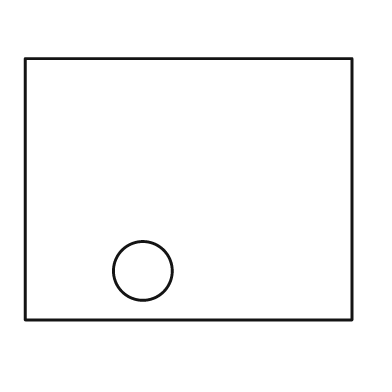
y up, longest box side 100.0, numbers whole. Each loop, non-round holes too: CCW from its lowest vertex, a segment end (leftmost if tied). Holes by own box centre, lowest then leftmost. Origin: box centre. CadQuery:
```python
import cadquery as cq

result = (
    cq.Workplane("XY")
    .moveTo(-50.0, -40.0)
    .lineTo(50.0, -40.0)
    .lineTo(50.0, 40.0)
    .lineTo(-50.0, 40.0)
    .close()
    .moveTo(-14.0, -25.0)
    .circle(9.0)
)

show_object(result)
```